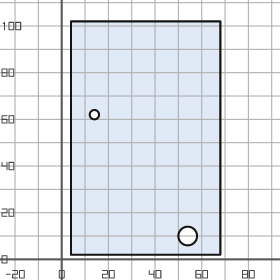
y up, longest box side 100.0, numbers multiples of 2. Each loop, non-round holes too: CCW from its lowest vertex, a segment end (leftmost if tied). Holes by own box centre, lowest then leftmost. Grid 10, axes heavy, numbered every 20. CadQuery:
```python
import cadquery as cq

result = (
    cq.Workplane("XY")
    .moveTo(4.0, 2.0)
    .lineTo(68.0, 2.0)
    .lineTo(68.0, 102.0)
    .lineTo(4.0, 102.0)
    .close()
    .moveTo(54.0, 10.0)
    .circle(4.0)
    .moveTo(14.0, 62.0)
    .circle(2.0)
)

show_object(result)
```